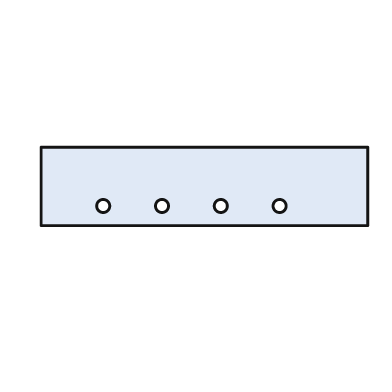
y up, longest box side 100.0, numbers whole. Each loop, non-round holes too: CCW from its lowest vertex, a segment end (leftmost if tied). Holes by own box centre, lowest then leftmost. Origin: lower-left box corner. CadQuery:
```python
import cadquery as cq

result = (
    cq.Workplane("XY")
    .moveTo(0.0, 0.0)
    .lineTo(100.0, 0.0)
    .lineTo(100.0, 24.0)
    .lineTo(0.0, 24.0)
    .close()
    .moveTo(19.0, 6.0)
    .circle(2.0)
    .moveTo(37.0, 6.0)
    .circle(2.0)
    .moveTo(55.0, 6.0)
    .circle(2.0)
    .moveTo(73.0, 6.0)
    .circle(2.0)
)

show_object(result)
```